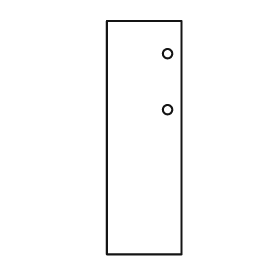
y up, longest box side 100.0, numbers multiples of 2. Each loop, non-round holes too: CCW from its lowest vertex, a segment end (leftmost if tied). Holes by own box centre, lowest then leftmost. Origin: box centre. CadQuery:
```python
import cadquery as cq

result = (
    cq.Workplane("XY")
    .moveTo(-16.0, -50.0)
    .lineTo(16.0, -50.0)
    .lineTo(16.0, 50.0)
    .lineTo(-16.0, 50.0)
    .close()
    .moveTo(10.0, 12.0)
    .circle(2.0)
    .moveTo(10.0, 36.0)
    .circle(2.0)
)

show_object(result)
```